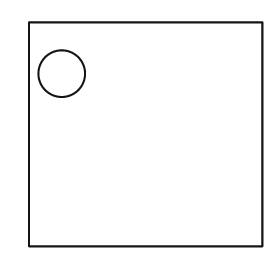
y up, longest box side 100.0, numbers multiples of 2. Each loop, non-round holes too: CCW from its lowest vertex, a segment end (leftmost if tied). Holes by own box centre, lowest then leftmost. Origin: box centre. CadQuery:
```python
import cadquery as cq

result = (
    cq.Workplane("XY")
    .moveTo(-50.0, -48.0)
    .lineTo(50.0, -48.0)
    .lineTo(50.0, 48.0)
    .lineTo(-50.0, 48.0)
    .close()
    .moveTo(-36.0, 26.0)
    .circle(10.0)
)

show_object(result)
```